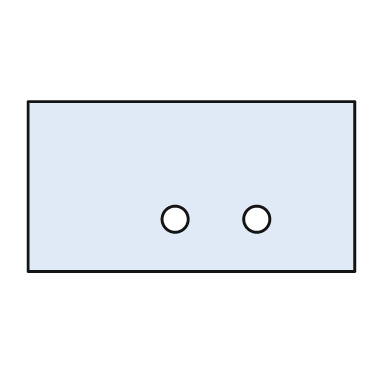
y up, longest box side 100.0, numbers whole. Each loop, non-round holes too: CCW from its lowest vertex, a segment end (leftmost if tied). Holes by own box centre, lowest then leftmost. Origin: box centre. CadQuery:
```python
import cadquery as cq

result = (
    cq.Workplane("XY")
    .moveTo(-50.0, -26.0)
    .lineTo(50.0, -26.0)
    .lineTo(50.0, 26.0)
    .lineTo(-50.0, 26.0)
    .close()
    .moveTo(-5.0, -10.0)
    .circle(4.0)
    .moveTo(20.0, -10.0)
    .circle(4.0)
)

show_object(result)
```